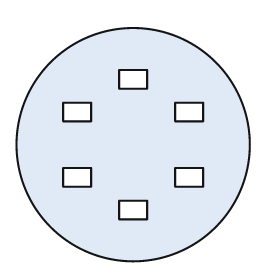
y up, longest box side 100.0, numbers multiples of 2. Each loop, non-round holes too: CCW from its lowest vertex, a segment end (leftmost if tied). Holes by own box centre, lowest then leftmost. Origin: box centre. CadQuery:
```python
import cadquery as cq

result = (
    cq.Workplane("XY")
    .moveTo(0.0, 0.0)
    .circle(50.0)
    .moveTo(-6.0, -32.0)
    .lineTo(6.0, -32.0)
    .lineTo(6.0, -24.0)
    .lineTo(-6.0, -24.0)
    .close()
    .moveTo(-30.0, -18.0)
    .lineTo(-18.0, -18.0)
    .lineTo(-18.0, -10.0)
    .lineTo(-30.0, -10.0)
    .close()
    .moveTo(18.0, -18.0)
    .lineTo(30.0, -18.0)
    .lineTo(30.0, -10.0)
    .lineTo(18.0, -10.0)
    .close()
    .moveTo(-30.0, 10.0)
    .lineTo(-18.0, 10.0)
    .lineTo(-18.0, 18.0)
    .lineTo(-30.0, 18.0)
    .close()
    .moveTo(18.0, 10.0)
    .lineTo(30.0, 10.0)
    .lineTo(30.0, 18.0)
    .lineTo(18.0, 18.0)
    .close()
    .moveTo(-6.0, 24.0)
    .lineTo(6.0, 24.0)
    .lineTo(6.0, 32.0)
    .lineTo(-6.0, 32.0)
    .close()
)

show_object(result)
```